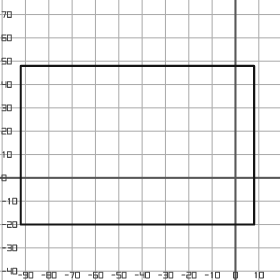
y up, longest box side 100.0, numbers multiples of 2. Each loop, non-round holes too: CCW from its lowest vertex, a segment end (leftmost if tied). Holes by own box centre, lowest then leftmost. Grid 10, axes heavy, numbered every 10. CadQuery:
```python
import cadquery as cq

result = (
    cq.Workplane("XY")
    .moveTo(-92.0, -20.0)
    .lineTo(8.0, -20.0)
    .lineTo(8.0, 48.0)
    .lineTo(-92.0, 48.0)
    .close()
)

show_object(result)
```